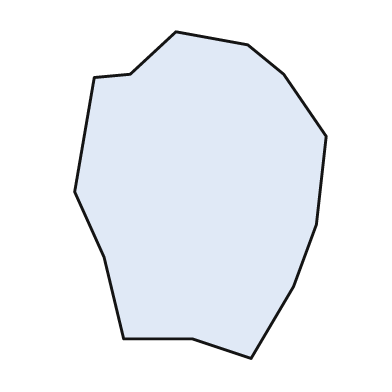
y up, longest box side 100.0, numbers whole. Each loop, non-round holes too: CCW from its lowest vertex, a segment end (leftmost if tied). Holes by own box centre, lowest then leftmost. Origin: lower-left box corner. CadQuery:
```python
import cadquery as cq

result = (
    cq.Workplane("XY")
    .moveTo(54.0, 0.0)
    .lineTo(67.0, 22.0)
    .lineTo(74.0, 41.0)
    .lineTo(77.0, 68.0)
    .lineTo(64.0, 87.0)
    .lineTo(53.0, 96.0)
    .lineTo(31.0, 100.0)
    .lineTo(17.0, 87.0)
    .lineTo(6.0, 86.0)
    .lineTo(0.0, 51.0)
    .lineTo(9.0, 31.0)
    .lineTo(15.0, 6.0)
    .lineTo(36.0, 6.0)
    .close()
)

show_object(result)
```